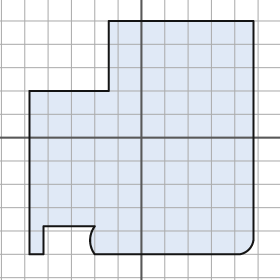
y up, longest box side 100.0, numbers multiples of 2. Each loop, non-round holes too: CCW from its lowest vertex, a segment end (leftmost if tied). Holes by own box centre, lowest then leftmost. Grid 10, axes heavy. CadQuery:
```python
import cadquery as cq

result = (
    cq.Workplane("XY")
    .moveTo(-48.0, -50.0)
    .lineTo(-42.0, -50.0)
    .lineTo(-42.0, -38.0)
    .lineTo(-20.0, -38.0)
    .threePointArc((-22.0, -44.0), (-20.0, -50.0))
    .lineTo(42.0, -50.0)
    .threePointArc((46.0, -48.0), (48.0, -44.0))
    .lineTo(48.0, 50.0)
    .lineTo(-14.0, 50.0)
    .lineTo(-14.0, 20.0)
    .lineTo(-48.0, 20.0)
    .close()
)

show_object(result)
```